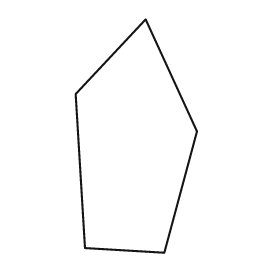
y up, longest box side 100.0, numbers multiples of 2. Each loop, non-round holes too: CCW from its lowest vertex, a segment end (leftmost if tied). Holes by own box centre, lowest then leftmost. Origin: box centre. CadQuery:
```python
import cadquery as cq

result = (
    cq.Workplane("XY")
    .moveTo(12.0, -50.0)
    .lineTo(26.0, 2.0)
    .lineTo(4.0, 50.0)
    .lineTo(-26.0, 18.0)
    .lineTo(-22.0, -48.0)
    .close()
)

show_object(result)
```